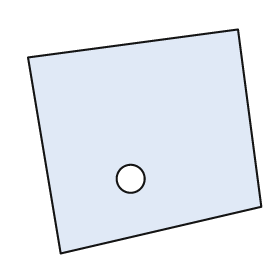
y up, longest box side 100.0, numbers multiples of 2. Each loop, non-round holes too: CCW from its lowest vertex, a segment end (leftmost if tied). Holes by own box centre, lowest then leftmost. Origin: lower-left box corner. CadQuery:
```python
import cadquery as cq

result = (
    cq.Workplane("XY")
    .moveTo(14.0, 0.0)
    .lineTo(100.0, 20.0)
    .lineTo(90.0, 96.0)
    .lineTo(0.0, 84.0)
    .close()
    .moveTo(44.0, 32.0)
    .circle(6.0)
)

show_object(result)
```